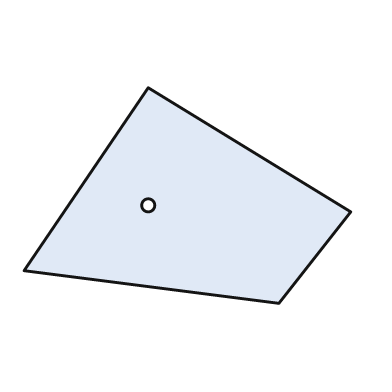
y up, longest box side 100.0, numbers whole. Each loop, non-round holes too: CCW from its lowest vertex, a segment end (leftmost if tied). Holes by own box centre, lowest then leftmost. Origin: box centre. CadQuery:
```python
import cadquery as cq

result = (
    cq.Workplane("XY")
    .moveTo(28.0, -33.0)
    .lineTo(50.0, -5.0)
    .lineTo(-12.0, 33.0)
    .lineTo(-50.0, -23.0)
    .close()
    .moveTo(-12.0, -3.0)
    .circle(2.0)
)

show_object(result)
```